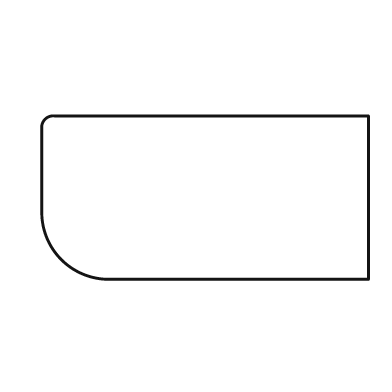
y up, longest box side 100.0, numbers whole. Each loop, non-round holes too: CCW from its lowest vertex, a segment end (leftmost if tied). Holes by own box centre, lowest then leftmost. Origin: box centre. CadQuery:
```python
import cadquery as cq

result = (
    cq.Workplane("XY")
    .moveTo(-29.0, -25.0)
    .lineTo(50.0, -25.0)
    .lineTo(50.0, 25.0)
    .lineTo(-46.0, 25.0)
    .threePointArc((-49.0, 24.0), (-50.0, 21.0))
    .lineTo(-50.0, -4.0)
    .threePointArc((-44.0, -19.0), (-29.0, -25.0))
    .close()
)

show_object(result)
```